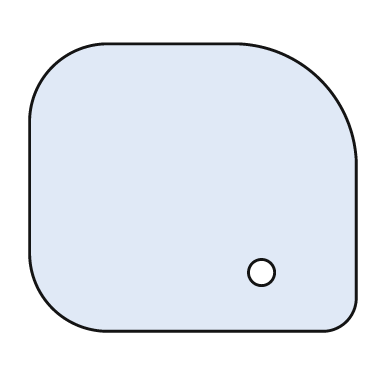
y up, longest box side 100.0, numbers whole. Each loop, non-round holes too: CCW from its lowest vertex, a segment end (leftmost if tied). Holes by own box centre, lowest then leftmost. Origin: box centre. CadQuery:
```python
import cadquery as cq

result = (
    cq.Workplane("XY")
    .moveTo(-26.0, -44.0)
    .lineTo(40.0, -44.0)
    .threePointArc((47.0, -41.0), (50.0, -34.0))
    .lineTo(50.0, 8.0)
    .threePointArc((39.0, 33.0), (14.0, 44.0))
    .lineTo(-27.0, 44.0)
    .threePointArc((-43.0, 37.0), (-50.0, 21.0))
    .lineTo(-50.0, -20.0)
    .threePointArc((-43.0, -37.0), (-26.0, -44.0))
    .close()
    .moveTo(21.0, -26.0)
    .circle(4.0)
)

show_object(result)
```